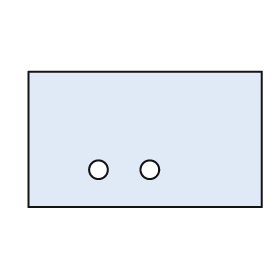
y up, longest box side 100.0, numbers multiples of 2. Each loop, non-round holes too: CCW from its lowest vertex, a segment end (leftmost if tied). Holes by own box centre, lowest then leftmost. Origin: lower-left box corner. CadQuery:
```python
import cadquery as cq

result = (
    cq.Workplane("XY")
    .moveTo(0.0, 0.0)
    .lineTo(100.0, 0.0)
    .lineTo(100.0, 58.0)
    .lineTo(0.0, 58.0)
    .close()
    .moveTo(30.0, 16.0)
    .circle(4.0)
    .moveTo(52.0, 16.0)
    .circle(4.0)
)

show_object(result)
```